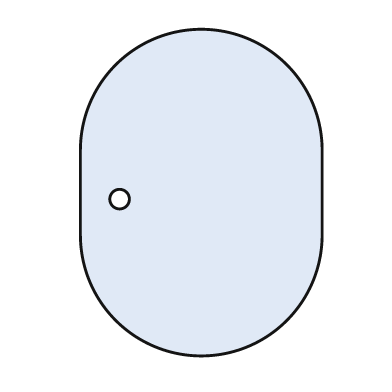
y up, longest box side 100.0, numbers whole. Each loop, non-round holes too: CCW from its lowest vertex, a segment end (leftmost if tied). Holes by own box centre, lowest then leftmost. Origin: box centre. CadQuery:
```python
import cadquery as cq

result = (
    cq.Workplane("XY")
    .moveTo(-37.0, -13.0)
    .threePointArc((0.0, -50.0), (37.0, -13.0))
    .lineTo(37.0, 13.0)
    .threePointArc((0.0, 50.0), (-37.0, 13.0))
    .close()
    .moveTo(-25.0, -2.0)
    .circle(3.0)
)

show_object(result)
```